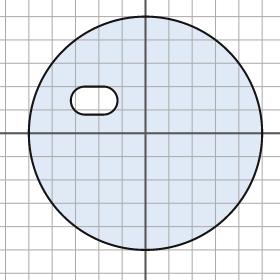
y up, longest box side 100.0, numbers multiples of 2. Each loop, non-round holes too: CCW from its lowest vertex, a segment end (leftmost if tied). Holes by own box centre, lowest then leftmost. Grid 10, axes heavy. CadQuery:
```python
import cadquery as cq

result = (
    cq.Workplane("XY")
    .moveTo(0.0, 0.0)
    .circle(50.0)
    .moveTo(-26.0, 8.0)
    .lineTo(-18.0, 8.0)
    .threePointArc((-12.0, 14.0), (-18.0, 20.0))
    .lineTo(-26.0, 20.0)
    .threePointArc((-32.0, 14.0), (-26.0, 8.0))
    .close()
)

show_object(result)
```